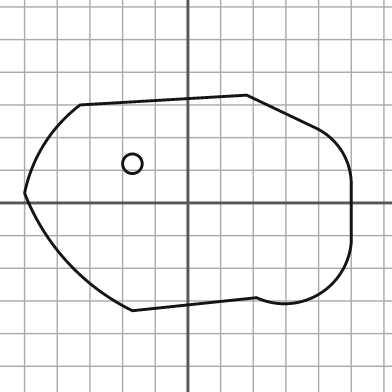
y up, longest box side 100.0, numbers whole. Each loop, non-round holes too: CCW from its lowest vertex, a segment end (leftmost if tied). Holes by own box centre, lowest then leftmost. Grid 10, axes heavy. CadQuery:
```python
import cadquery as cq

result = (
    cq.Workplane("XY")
    .moveTo(-17.0, -33.0)
    .lineTo(21.0, -29.0)
    .threePointArc((40.0, -28.0), (50.0, -12.0))
    .lineTo(50.0, 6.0)
    .threePointArc((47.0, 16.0), (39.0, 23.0))
    .lineTo(18.0, 33.0)
    .lineTo(-33.0, 30.0)
    .threePointArc((-44.0, 18.0), (-50.0, 3.0))
    .threePointArc((-37.0, -18.0), (-17.0, -33.0))
    .close()
    .moveTo(-17.0, 12.0)
    .circle(3.0)
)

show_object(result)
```